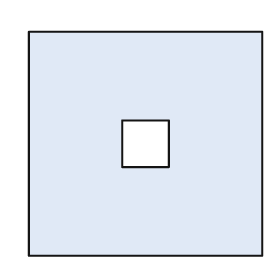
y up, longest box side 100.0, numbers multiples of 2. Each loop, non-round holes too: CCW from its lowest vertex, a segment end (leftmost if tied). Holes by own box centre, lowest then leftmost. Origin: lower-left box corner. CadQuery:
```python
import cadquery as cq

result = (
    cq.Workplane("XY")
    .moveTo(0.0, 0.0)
    .lineTo(100.0, 0.0)
    .lineTo(100.0, 96.0)
    .lineTo(0.0, 96.0)
    .close()
    .moveTo(40.0, 38.0)
    .lineTo(60.0, 38.0)
    .lineTo(60.0, 58.0)
    .lineTo(40.0, 58.0)
    .close()
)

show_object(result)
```